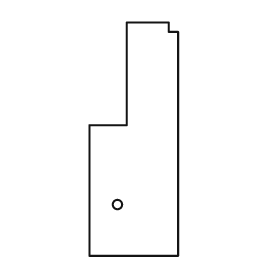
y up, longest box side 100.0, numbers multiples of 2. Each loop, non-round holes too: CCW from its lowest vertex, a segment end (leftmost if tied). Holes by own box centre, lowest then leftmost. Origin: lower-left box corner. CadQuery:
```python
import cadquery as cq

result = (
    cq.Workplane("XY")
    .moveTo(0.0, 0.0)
    .lineTo(38.0, 0.0)
    .lineTo(38.0, 96.0)
    .lineTo(34.0, 96.0)
    .lineTo(34.0, 100.0)
    .lineTo(16.0, 100.0)
    .lineTo(16.0, 56.0)
    .lineTo(0.0, 56.0)
    .close()
    .moveTo(12.0, 22.0)
    .circle(2.0)
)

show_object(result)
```